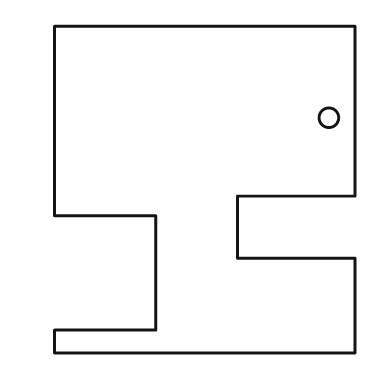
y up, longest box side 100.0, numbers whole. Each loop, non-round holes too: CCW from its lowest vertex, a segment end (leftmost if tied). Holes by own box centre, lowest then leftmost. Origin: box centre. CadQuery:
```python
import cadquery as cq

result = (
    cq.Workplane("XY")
    .moveTo(-46.0, -50.0)
    .lineTo(46.0, -50.0)
    .lineTo(46.0, -21.0)
    .lineTo(10.0, -21.0)
    .lineTo(10.0, -2.0)
    .lineTo(46.0, -2.0)
    .lineTo(46.0, 50.0)
    .lineTo(-46.0, 50.0)
    .lineTo(-46.0, -8.0)
    .lineTo(-15.0, -8.0)
    .lineTo(-15.0, -43.0)
    .lineTo(-46.0, -43.0)
    .close()
    .moveTo(38.0, 22.0)
    .circle(3.0)
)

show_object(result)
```